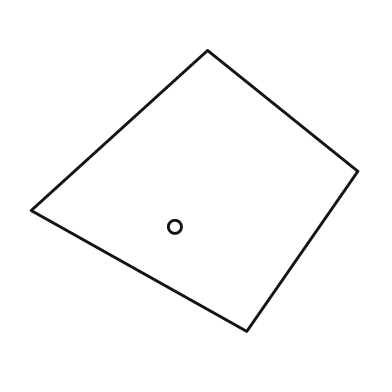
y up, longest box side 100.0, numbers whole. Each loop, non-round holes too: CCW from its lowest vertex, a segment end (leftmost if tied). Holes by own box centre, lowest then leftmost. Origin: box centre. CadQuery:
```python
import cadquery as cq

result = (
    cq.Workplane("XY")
    .moveTo(16.0, -43.0)
    .lineTo(50.0, 6.0)
    .lineTo(4.0, 43.0)
    .lineTo(-50.0, -6.0)
    .close()
    .moveTo(-6.0, -11.0)
    .circle(2.0)
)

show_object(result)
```